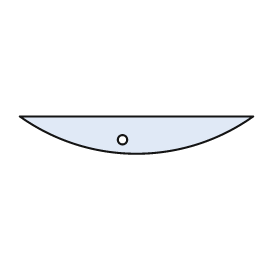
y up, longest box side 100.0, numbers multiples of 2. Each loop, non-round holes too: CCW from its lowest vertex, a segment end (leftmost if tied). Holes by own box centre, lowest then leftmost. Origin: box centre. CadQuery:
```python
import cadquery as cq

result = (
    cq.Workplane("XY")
    .moveTo(-50.0, 8.0)
    .threePointArc((0.0, -8.0), (50.0, 8.0))
    .close()
    .moveTo(-6.0, -2.0)
    .circle(2.0)
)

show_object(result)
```